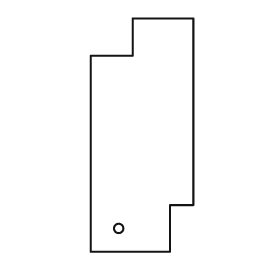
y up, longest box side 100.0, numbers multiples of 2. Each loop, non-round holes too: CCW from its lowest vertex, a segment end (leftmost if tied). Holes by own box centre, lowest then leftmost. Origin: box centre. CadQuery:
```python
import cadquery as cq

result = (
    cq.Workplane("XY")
    .moveTo(-22.0, -50.0)
    .lineTo(12.0, -50.0)
    .lineTo(12.0, -30.0)
    .lineTo(22.0, -30.0)
    .lineTo(22.0, 50.0)
    .lineTo(-4.0, 50.0)
    .lineTo(-4.0, 34.0)
    .lineTo(-22.0, 34.0)
    .close()
    .moveTo(-10.0, -40.0)
    .circle(2.0)
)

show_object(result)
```